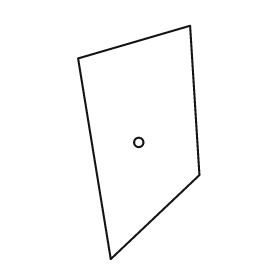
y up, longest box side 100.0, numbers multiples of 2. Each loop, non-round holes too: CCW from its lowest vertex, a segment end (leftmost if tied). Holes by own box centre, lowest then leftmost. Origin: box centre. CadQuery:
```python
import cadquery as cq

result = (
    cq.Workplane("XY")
    .moveTo(-12.0, -50.0)
    .lineTo(26.0, -14.0)
    .lineTo(22.0, 50.0)
    .lineTo(-26.0, 36.0)
    .close()
    .moveTo(0.0, 0.0)
    .circle(2.0)
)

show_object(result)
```